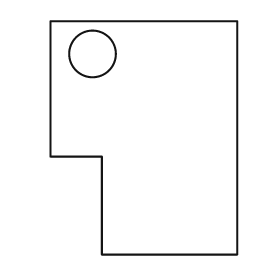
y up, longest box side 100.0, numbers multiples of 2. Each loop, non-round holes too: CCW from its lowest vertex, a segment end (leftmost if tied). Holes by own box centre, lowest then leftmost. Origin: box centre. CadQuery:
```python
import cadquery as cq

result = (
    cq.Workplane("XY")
    .moveTo(-18.0, -50.0)
    .lineTo(40.0, -50.0)
    .lineTo(40.0, 50.0)
    .lineTo(-40.0, 50.0)
    .lineTo(-40.0, -8.0)
    .lineTo(-18.0, -8.0)
    .close()
    .moveTo(-22.0, 36.0)
    .circle(10.0)
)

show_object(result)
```